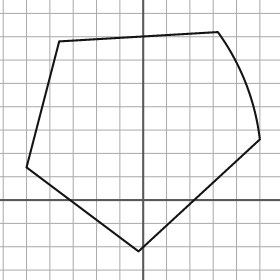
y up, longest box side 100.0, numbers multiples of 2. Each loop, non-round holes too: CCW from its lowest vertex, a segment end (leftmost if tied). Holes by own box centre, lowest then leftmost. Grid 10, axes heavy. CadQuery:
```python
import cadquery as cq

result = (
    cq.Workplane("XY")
    .moveTo(-2.0, -22.0)
    .lineTo(50.0, 26.0)
    .threePointArc((44.0, 50.0), (32.0, 72.0))
    .lineTo(-36.0, 68.0)
    .lineTo(-50.0, 14.0)
    .close()
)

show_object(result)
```